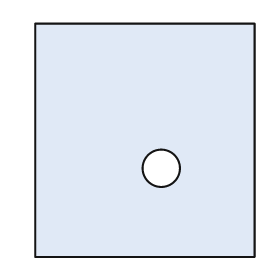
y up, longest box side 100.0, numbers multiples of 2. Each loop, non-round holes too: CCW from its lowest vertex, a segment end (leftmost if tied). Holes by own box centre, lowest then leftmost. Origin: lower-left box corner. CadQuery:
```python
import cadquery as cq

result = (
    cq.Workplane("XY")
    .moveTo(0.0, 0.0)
    .lineTo(94.0, 0.0)
    .lineTo(94.0, 100.0)
    .lineTo(0.0, 100.0)
    .close()
    .moveTo(54.0, 38.0)
    .circle(8.0)
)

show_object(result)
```